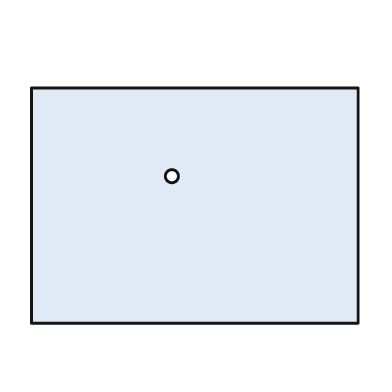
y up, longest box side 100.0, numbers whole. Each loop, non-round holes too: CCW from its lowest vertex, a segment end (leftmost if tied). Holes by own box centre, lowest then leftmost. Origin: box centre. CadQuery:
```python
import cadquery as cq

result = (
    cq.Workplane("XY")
    .moveTo(-50.0, -36.0)
    .lineTo(50.0, -36.0)
    .lineTo(50.0, 36.0)
    .lineTo(-50.0, 36.0)
    .close()
    .moveTo(-7.0, 9.0)
    .circle(2.0)
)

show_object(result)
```